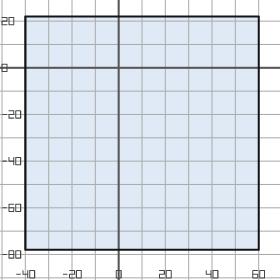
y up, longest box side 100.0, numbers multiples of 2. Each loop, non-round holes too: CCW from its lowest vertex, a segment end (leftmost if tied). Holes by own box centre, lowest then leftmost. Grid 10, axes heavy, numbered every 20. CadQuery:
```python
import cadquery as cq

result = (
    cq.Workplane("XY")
    .moveTo(-40.0, -78.0)
    .lineTo(60.0, -78.0)
    .lineTo(60.0, 22.0)
    .lineTo(-40.0, 22.0)
    .close()
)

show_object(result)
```